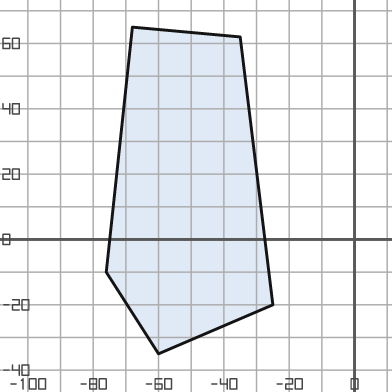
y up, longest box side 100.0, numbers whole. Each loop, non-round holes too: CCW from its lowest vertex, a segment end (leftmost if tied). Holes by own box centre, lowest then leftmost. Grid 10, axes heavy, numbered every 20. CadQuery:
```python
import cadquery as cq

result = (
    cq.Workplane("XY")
    .moveTo(-60.0, -35.0)
    .lineTo(-25.0, -20.0)
    .lineTo(-35.0, 62.0)
    .lineTo(-68.0, 65.0)
    .lineTo(-76.0, -10.0)
    .close()
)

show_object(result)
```